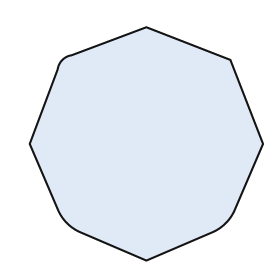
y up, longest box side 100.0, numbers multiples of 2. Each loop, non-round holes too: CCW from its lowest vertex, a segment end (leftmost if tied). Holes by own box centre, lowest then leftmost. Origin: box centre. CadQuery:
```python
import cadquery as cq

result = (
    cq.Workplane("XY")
    .moveTo(0.0, -50.0)
    .lineTo(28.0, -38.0)
    .threePointArc((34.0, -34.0), (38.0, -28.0))
    .lineTo(50.0, 0.0)
    .lineTo(36.0, 36.0)
    .lineTo(0.0, 50.0)
    .lineTo(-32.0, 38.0)
    .threePointArc((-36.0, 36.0), (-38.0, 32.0))
    .lineTo(-50.0, 0.0)
    .lineTo(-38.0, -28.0)
    .threePointArc((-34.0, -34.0), (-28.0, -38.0))
    .close()
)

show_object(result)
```